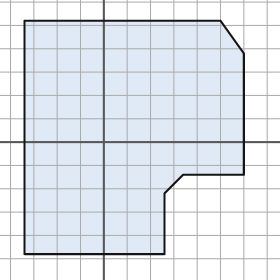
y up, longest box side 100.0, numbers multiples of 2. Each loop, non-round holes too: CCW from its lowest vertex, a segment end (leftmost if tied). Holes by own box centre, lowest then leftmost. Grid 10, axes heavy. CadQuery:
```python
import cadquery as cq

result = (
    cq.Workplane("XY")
    .moveTo(-34.0, -48.0)
    .lineTo(26.0, -48.0)
    .lineTo(26.0, -22.0)
    .lineTo(34.0, -14.0)
    .lineTo(60.0, -14.0)
    .lineTo(60.0, 38.0)
    .lineTo(50.0, 52.0)
    .lineTo(-34.0, 52.0)
    .close()
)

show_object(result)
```